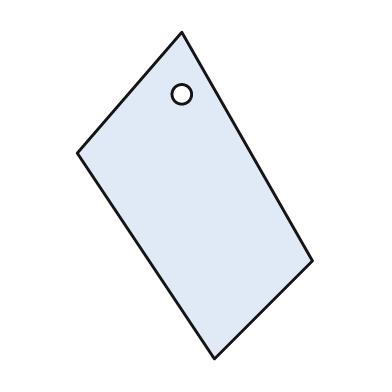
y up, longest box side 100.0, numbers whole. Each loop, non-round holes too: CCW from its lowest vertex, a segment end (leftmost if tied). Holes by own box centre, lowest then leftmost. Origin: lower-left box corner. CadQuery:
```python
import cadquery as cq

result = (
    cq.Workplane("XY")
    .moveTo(42.0, 0.0)
    .lineTo(72.0, 30.0)
    .lineTo(32.0, 100.0)
    .lineTo(0.0, 63.0)
    .close()
    .moveTo(32.0, 81.0)
    .circle(3.0)
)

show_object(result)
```